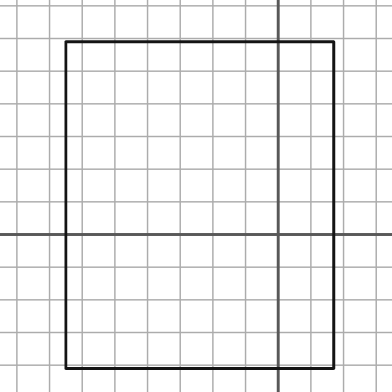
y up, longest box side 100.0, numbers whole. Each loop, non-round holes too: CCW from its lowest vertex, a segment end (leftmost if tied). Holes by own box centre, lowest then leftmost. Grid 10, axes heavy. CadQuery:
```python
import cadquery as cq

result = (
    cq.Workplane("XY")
    .moveTo(-65.0, -41.0)
    .lineTo(17.0, -41.0)
    .lineTo(17.0, 59.0)
    .lineTo(-65.0, 59.0)
    .close()
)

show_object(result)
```